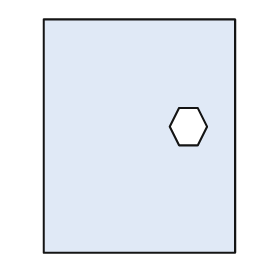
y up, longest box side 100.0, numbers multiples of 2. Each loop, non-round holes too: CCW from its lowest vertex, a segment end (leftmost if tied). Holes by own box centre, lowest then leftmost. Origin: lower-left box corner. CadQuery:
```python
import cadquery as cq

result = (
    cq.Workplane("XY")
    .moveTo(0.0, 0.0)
    .lineTo(82.0, 0.0)
    .lineTo(82.0, 100.0)
    .lineTo(0.0, 100.0)
    .close()
    .moveTo(58.0, 46.0)
    .lineTo(66.0, 46.0)
    .lineTo(70.0, 54.0)
    .lineTo(66.0, 62.0)
    .lineTo(58.0, 62.0)
    .lineTo(54.0, 54.0)
    .close()
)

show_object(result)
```